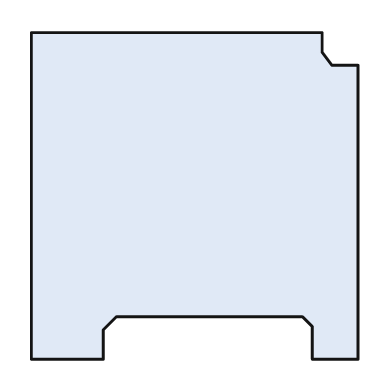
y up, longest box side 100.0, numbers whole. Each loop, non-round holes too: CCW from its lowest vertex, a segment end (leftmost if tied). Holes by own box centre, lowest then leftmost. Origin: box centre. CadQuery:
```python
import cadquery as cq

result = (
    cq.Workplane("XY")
    .moveTo(-50.0, -50.0)
    .lineTo(-28.0, -50.0)
    .lineTo(-28.0, -41.0)
    .lineTo(-24.0, -37.0)
    .lineTo(33.0, -37.0)
    .lineTo(36.0, -40.0)
    .lineTo(36.0, -50.0)
    .lineTo(50.0, -50.0)
    .lineTo(50.0, 40.0)
    .lineTo(42.0, 40.0)
    .lineTo(39.0, 44.0)
    .lineTo(39.0, 50.0)
    .lineTo(-50.0, 50.0)
    .close()
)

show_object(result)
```